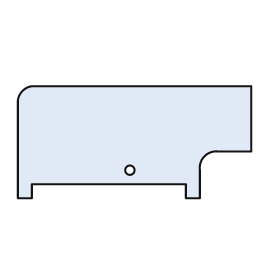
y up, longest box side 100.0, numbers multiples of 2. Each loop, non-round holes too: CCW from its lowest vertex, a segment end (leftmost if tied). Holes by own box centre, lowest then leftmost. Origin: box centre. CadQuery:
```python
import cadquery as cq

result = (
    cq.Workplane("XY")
    .moveTo(-50.0, -24.0)
    .lineTo(-44.0, -24.0)
    .lineTo(-44.0, -18.0)
    .lineTo(22.0, -18.0)
    .lineTo(22.0, -24.0)
    .lineTo(28.0, -24.0)
    .lineTo(28.0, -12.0)
    .threePointArc((30.0, -6.0), (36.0, -4.0))
    .lineTo(50.0, -4.0)
    .lineTo(50.0, 24.0)
    .lineTo(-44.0, 24.0)
    .threePointArc((-48.0, 22.0), (-50.0, 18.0))
    .close()
    .moveTo(-2.0, -12.0)
    .circle(2.0)
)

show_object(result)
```